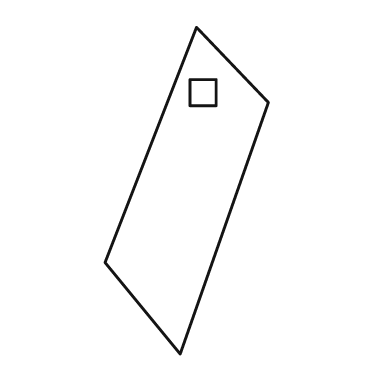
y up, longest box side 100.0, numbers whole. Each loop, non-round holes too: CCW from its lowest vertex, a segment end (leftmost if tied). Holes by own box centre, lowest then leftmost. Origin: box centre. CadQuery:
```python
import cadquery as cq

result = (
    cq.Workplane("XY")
    .moveTo(-2.0, -50.0)
    .lineTo(25.0, 27.0)
    .lineTo(3.0, 50.0)
    .lineTo(-25.0, -22.0)
    .close()
    .moveTo(1.0, 26.0)
    .lineTo(9.0, 26.0)
    .lineTo(9.0, 34.0)
    .lineTo(1.0, 34.0)
    .close()
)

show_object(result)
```